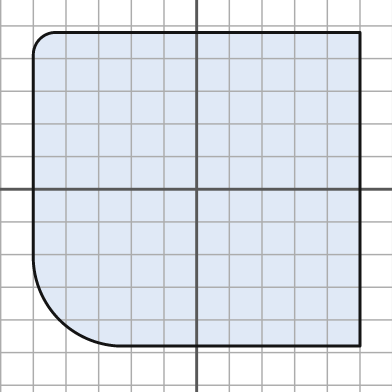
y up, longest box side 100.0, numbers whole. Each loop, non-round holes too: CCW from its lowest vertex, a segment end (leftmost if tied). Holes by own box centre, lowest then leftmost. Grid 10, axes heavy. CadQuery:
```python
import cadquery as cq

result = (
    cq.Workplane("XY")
    .moveTo(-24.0, -48.0)
    .lineTo(50.0, -48.0)
    .lineTo(50.0, 48.0)
    .lineTo(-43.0, 48.0)
    .threePointArc((-48.0, 46.0), (-50.0, 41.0))
    .lineTo(-50.0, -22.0)
    .threePointArc((-42.0, -40.0), (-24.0, -48.0))
    .close()
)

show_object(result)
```